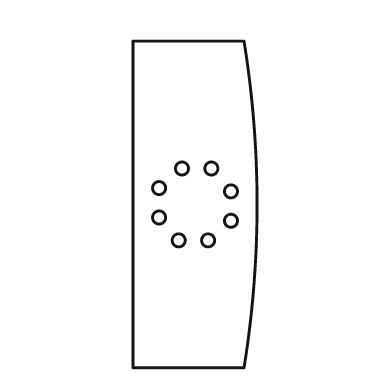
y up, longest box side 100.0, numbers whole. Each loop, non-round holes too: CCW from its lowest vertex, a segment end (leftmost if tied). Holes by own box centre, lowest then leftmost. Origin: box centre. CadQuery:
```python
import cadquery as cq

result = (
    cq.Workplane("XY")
    .moveTo(-19.0, -50.0)
    .lineTo(15.0, -50.0)
    .threePointArc((19.0, 0.0), (15.0, 50.0))
    .lineTo(-19.0, 50.0)
    .close()
    .moveTo(-5.0, -11.0)
    .circle(2.0)
    .moveTo(4.0, -11.0)
    .circle(2.0)
    .moveTo(11.0, -5.0)
    .circle(2.0)
    .moveTo(-11.0, -4.0)
    .circle(2.0)
    .moveTo(11.0, 4.0)
    .circle(2.0)
    .moveTo(-11.0, 5.0)
    .circle(2.0)
    .moveTo(-4.0, 11.0)
    .circle(2.0)
    .moveTo(5.0, 11.0)
    .circle(2.0)
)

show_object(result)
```